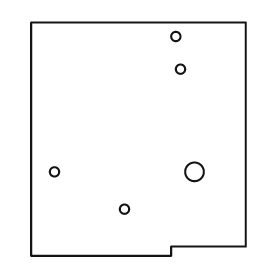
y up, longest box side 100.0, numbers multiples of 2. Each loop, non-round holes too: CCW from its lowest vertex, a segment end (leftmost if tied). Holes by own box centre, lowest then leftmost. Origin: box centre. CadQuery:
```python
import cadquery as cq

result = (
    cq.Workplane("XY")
    .moveTo(-46.0, -50.0)
    .lineTo(14.0, -50.0)
    .lineTo(14.0, -46.0)
    .lineTo(46.0, -46.0)
    .lineTo(46.0, 50.0)
    .lineTo(-46.0, 50.0)
    .close()
    .moveTo(-6.0, -30.0)
    .circle(2.0)
    .moveTo(-36.0, -14.0)
    .circle(2.0)
    .moveTo(24.0, -14.0)
    .circle(4.0)
    .moveTo(18.0, 30.0)
    .circle(2.0)
    .moveTo(16.0, 44.0)
    .circle(2.0)
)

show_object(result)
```